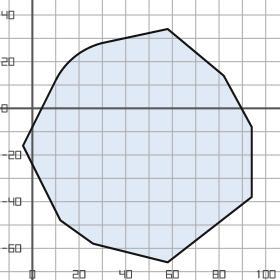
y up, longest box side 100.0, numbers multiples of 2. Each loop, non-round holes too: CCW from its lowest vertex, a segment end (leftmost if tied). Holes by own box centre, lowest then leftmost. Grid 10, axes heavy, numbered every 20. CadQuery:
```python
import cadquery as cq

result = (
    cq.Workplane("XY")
    .moveTo(58.0, -66.0)
    .lineTo(94.0, -38.0)
    .lineTo(94.0, -8.0)
    .lineTo(82.0, 14.0)
    .lineTo(58.0, 34.0)
    .lineTo(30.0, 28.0)
    .threePointArc((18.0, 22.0), (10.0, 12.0))
    .lineTo(-4.0, -16.0)
    .lineTo(12.0, -48.0)
    .lineTo(26.0, -58.0)
    .close()
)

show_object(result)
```